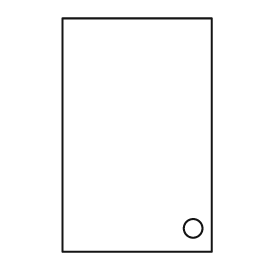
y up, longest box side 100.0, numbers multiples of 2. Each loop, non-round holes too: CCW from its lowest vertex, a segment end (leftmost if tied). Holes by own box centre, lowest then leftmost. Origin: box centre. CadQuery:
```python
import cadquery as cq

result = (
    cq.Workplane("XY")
    .moveTo(-32.0, -50.0)
    .lineTo(32.0, -50.0)
    .lineTo(32.0, 50.0)
    .lineTo(-32.0, 50.0)
    .close()
    .moveTo(24.0, -40.0)
    .circle(4.0)
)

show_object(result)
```